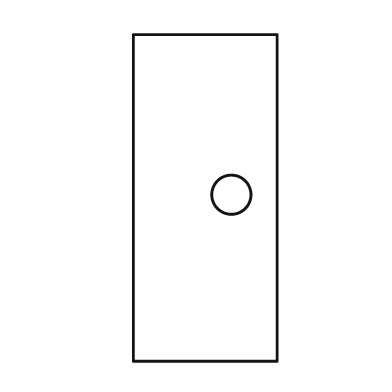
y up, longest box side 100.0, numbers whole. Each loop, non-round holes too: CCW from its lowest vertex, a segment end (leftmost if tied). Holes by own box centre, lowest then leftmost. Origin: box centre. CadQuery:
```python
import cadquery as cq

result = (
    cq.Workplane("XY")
    .moveTo(-22.0, -50.0)
    .lineTo(22.0, -50.0)
    .lineTo(22.0, 50.0)
    .lineTo(-22.0, 50.0)
    .close()
    .moveTo(8.0, 1.0)
    .circle(6.0)
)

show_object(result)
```